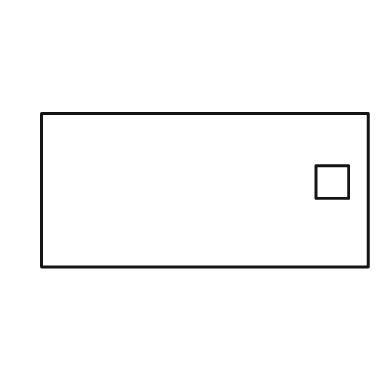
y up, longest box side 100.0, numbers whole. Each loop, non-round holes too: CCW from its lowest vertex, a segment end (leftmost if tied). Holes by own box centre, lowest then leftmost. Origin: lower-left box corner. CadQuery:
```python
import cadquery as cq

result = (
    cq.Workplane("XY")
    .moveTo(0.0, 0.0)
    .lineTo(100.0, 0.0)
    .lineTo(100.0, 47.0)
    .lineTo(0.0, 47.0)
    .close()
    .moveTo(84.0, 21.0)
    .lineTo(94.0, 21.0)
    .lineTo(94.0, 31.0)
    .lineTo(84.0, 31.0)
    .close()
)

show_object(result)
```